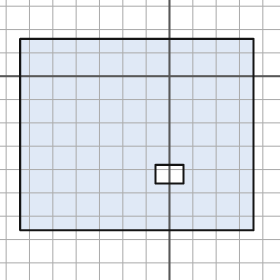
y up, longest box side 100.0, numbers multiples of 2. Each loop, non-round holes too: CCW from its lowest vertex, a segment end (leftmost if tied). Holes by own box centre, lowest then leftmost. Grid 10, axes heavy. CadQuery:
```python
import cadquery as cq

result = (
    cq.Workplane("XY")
    .moveTo(-64.0, -66.0)
    .lineTo(36.0, -66.0)
    .lineTo(36.0, 16.0)
    .lineTo(-64.0, 16.0)
    .close()
    .moveTo(-6.0, -46.0)
    .lineTo(6.0, -46.0)
    .lineTo(6.0, -38.0)
    .lineTo(-6.0, -38.0)
    .close()
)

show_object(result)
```